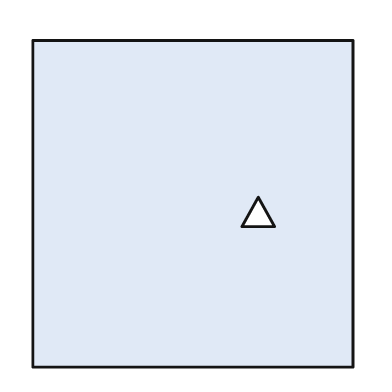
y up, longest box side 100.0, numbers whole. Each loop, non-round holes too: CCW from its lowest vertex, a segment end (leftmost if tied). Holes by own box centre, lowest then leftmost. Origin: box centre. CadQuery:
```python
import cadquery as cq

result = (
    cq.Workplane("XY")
    .moveTo(-49.0, -50.0)
    .lineTo(49.0, -50.0)
    .lineTo(49.0, 50.0)
    .lineTo(-49.0, 50.0)
    .close()
    .moveTo(15.0, -7.0)
    .lineTo(25.0, -7.0)
    .lineTo(20.0, 2.0)
    .close()
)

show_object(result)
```